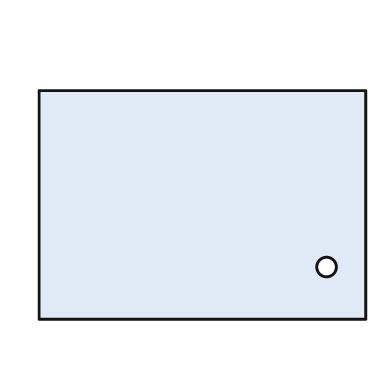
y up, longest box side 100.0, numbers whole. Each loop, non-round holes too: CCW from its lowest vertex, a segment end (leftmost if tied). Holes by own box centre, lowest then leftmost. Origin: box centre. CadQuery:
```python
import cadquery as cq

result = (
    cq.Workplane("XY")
    .moveTo(-50.0, -35.0)
    .lineTo(50.0, -35.0)
    .lineTo(50.0, 35.0)
    .lineTo(-50.0, 35.0)
    .close()
    .moveTo(38.0, -19.0)
    .circle(3.0)
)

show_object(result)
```